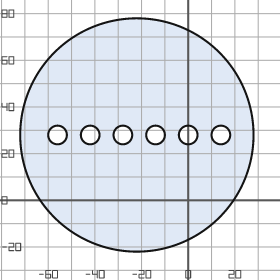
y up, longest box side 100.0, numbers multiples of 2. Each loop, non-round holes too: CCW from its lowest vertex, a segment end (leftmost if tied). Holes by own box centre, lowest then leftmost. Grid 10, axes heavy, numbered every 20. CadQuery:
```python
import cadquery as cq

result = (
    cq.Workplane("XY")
    .moveTo(-22.0, 28.0)
    .circle(50.0)
    .moveTo(-56.0, 28.0)
    .circle(4.0)
    .moveTo(-42.0, 28.0)
    .circle(4.0)
    .moveTo(-28.0, 28.0)
    .circle(4.0)
    .moveTo(-14.0, 28.0)
    .circle(4.0)
    .moveTo(0.0, 28.0)
    .circle(4.0)
    .moveTo(14.0, 28.0)
    .circle(4.0)
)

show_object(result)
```